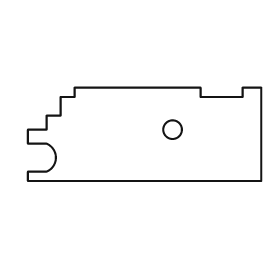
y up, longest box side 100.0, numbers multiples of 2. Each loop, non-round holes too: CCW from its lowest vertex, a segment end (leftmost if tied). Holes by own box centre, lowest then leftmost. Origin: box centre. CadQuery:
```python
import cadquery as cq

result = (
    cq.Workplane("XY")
    .moveTo(-50.0, -20.0)
    .lineTo(50.0, -20.0)
    .lineTo(50.0, 20.0)
    .lineTo(42.0, 20.0)
    .lineTo(42.0, 16.0)
    .lineTo(24.0, 16.0)
    .lineTo(24.0, 20.0)
    .lineTo(-30.0, 20.0)
    .lineTo(-30.0, 16.0)
    .lineTo(-36.0, 16.0)
    .lineTo(-36.0, 8.0)
    .lineTo(-42.0, 8.0)
    .lineTo(-42.0, 2.0)
    .lineTo(-50.0, 2.0)
    .lineTo(-50.0, -4.0)
    .lineTo(-42.0, -4.0)
    .threePointArc((-38.0, -10.0), (-42.0, -16.0))
    .lineTo(-50.0, -16.0)
    .close()
    .moveTo(12.0, 2.0)
    .circle(4.0)
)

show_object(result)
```